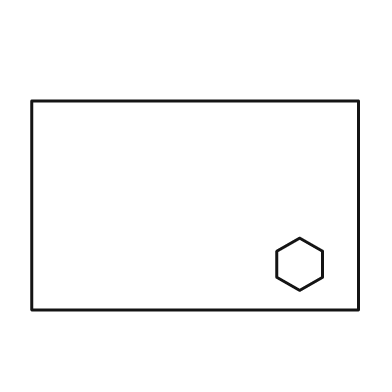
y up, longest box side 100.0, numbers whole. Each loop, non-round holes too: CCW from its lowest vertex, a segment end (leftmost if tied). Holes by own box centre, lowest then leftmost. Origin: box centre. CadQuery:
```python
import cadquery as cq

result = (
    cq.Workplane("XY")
    .moveTo(-50.0, -32.0)
    .lineTo(50.0, -32.0)
    .lineTo(50.0, 32.0)
    .lineTo(-50.0, 32.0)
    .close()
    .moveTo(32.0, -26.0)
    .lineTo(39.0, -22.0)
    .lineTo(39.0, -14.0)
    .lineTo(32.0, -10.0)
    .lineTo(25.0, -14.0)
    .lineTo(25.0, -22.0)
    .close()
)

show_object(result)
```